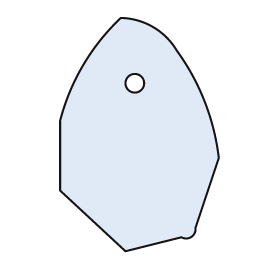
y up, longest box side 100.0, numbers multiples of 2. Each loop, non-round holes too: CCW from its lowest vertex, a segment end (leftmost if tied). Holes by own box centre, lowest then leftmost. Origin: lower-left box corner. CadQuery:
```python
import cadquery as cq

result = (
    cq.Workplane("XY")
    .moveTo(28.0, 0.0)
    .lineTo(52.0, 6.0)
    .threePointArc((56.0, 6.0), (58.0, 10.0))
    .lineTo(68.0, 40.0)
    .threePointArc((62.0, 64.0), (50.0, 86.0))
    .threePointArc((40.0, 96.0), (26.0, 100.0))
    .threePointArc((10.0, 80.0), (0.0, 56.0))
    .lineTo(0.0, 26.0)
    .close()
    .moveTo(32.0, 72.0)
    .circle(4.0)
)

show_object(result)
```